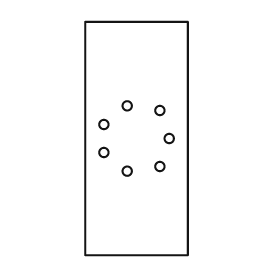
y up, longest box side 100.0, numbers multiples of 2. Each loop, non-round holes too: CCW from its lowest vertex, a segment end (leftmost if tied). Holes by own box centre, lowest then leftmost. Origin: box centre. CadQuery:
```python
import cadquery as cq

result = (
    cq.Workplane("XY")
    .moveTo(-22.0, -50.0)
    .lineTo(22.0, -50.0)
    .lineTo(22.0, 50.0)
    .lineTo(-22.0, 50.0)
    .close()
    .moveTo(-4.0, -14.0)
    .circle(2.0)
    .moveTo(10.0, -12.0)
    .circle(2.0)
    .moveTo(-14.0, -6.0)
    .circle(2.0)
    .moveTo(14.0, 0.0)
    .circle(2.0)
    .moveTo(-14.0, 6.0)
    .circle(2.0)
    .moveTo(10.0, 12.0)
    .circle(2.0)
    .moveTo(-4.0, 14.0)
    .circle(2.0)
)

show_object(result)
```